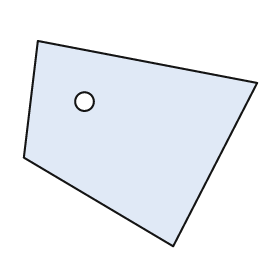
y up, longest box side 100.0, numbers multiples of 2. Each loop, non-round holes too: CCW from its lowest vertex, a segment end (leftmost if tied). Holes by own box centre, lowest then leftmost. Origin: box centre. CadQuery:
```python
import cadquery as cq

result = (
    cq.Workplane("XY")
    .moveTo(14.0, -44.0)
    .lineTo(50.0, 26.0)
    .lineTo(-44.0, 44.0)
    .lineTo(-50.0, -6.0)
    .close()
    .moveTo(-24.0, 18.0)
    .circle(4.0)
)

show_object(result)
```